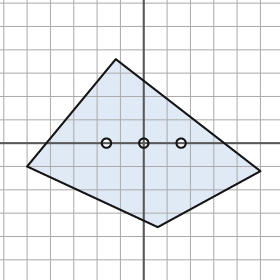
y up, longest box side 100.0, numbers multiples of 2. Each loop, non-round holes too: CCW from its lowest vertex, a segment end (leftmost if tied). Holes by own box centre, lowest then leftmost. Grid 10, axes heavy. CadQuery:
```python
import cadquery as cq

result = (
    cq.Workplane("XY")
    .moveTo(6.0, -36.0)
    .lineTo(50.0, -12.0)
    .lineTo(-12.0, 36.0)
    .lineTo(-50.0, -10.0)
    .close()
    .moveTo(-16.0, 0.0)
    .circle(2.0)
    .moveTo(0.0, 0.0)
    .circle(2.0)
    .moveTo(16.0, 0.0)
    .circle(2.0)
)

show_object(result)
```